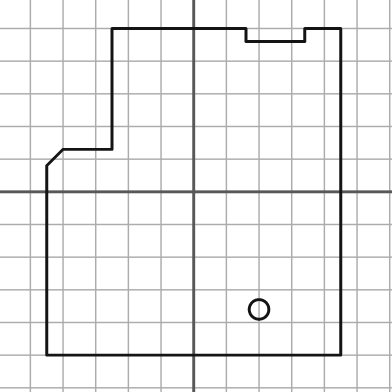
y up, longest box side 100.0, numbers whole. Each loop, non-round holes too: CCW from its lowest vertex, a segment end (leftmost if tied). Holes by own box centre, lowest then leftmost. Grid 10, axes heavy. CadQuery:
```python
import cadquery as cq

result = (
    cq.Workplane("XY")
    .moveTo(-45.0, -50.0)
    .lineTo(45.0, -50.0)
    .lineTo(45.0, 50.0)
    .lineTo(34.0, 50.0)
    .lineTo(34.0, 46.0)
    .lineTo(16.0, 46.0)
    .lineTo(16.0, 50.0)
    .lineTo(-25.0, 50.0)
    .lineTo(-25.0, 13.0)
    .lineTo(-40.0, 13.0)
    .lineTo(-45.0, 8.0)
    .close()
    .moveTo(20.0, -36.0)
    .circle(3.0)
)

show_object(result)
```